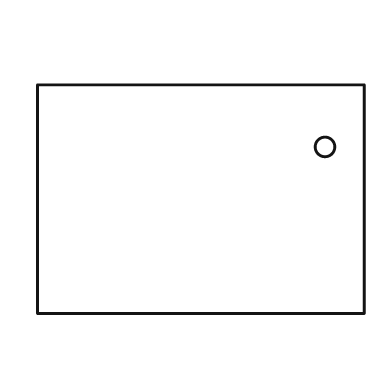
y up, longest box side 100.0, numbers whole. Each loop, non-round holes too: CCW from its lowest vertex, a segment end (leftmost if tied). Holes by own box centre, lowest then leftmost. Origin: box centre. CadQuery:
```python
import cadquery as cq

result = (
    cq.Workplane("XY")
    .moveTo(-50.0, -35.0)
    .lineTo(50.0, -35.0)
    .lineTo(50.0, 35.0)
    .lineTo(-50.0, 35.0)
    .close()
    .moveTo(38.0, 16.0)
    .circle(3.0)
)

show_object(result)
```